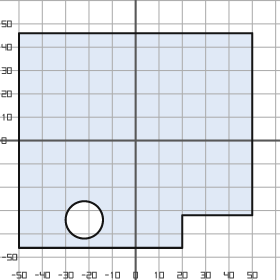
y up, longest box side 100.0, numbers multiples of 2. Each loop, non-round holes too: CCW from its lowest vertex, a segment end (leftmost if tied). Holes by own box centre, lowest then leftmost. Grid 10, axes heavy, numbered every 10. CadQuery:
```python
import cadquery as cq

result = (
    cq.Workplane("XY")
    .moveTo(-50.0, -46.0)
    .lineTo(20.0, -46.0)
    .lineTo(20.0, -32.0)
    .lineTo(50.0, -32.0)
    .lineTo(50.0, 46.0)
    .lineTo(-50.0, 46.0)
    .close()
    .moveTo(-22.0, -34.0)
    .circle(8.0)
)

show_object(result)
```